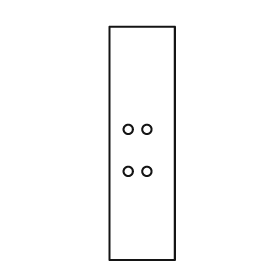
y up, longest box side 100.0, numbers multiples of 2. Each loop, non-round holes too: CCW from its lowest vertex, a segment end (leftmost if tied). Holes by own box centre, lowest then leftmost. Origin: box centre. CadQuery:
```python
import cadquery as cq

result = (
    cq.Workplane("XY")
    .moveTo(-14.0, -50.0)
    .lineTo(14.0, -50.0)
    .lineTo(14.0, 50.0)
    .lineTo(-14.0, 50.0)
    .close()
    .moveTo(-6.0, -12.0)
    .circle(2.0)
    .moveTo(2.0, -12.0)
    .circle(2.0)
    .moveTo(-6.0, 6.0)
    .circle(2.0)
    .moveTo(2.0, 6.0)
    .circle(2.0)
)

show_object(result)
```